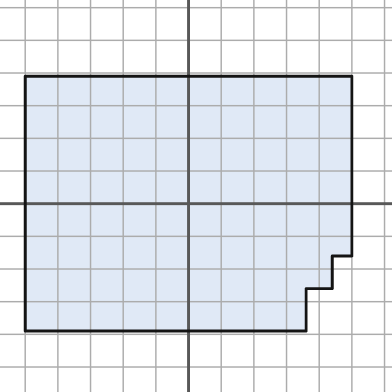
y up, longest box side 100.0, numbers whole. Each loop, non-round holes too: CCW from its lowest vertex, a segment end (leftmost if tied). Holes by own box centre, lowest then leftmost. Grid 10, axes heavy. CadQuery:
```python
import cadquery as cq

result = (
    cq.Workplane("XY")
    .moveTo(-50.0, -39.0)
    .lineTo(36.0, -39.0)
    .lineTo(36.0, -26.0)
    .lineTo(44.0, -26.0)
    .lineTo(44.0, -16.0)
    .lineTo(50.0, -16.0)
    .lineTo(50.0, 39.0)
    .lineTo(-50.0, 39.0)
    .close()
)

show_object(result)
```